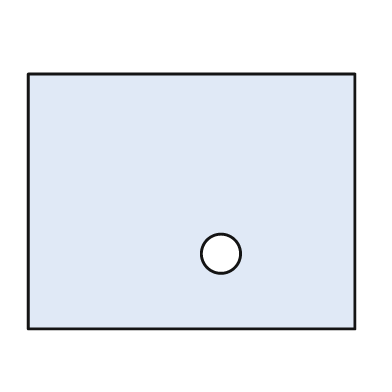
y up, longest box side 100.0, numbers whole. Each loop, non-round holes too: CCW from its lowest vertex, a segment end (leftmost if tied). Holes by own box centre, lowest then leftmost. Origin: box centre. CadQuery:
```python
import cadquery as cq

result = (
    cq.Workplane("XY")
    .moveTo(-50.0, -39.0)
    .lineTo(50.0, -39.0)
    .lineTo(50.0, 39.0)
    .lineTo(-50.0, 39.0)
    .close()
    .moveTo(9.0, -16.0)
    .circle(6.0)
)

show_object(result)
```